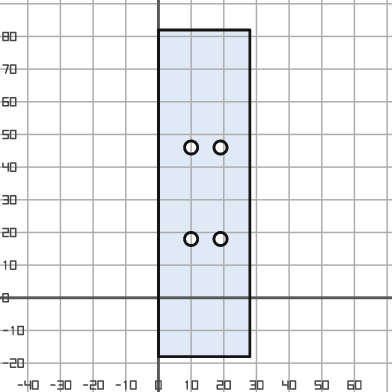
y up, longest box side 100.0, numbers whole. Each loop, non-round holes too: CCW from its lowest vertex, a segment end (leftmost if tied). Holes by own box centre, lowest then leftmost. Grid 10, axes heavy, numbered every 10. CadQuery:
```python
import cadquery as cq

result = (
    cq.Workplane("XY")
    .moveTo(0.0, -18.0)
    .lineTo(28.0, -18.0)
    .lineTo(28.0, 82.0)
    .lineTo(0.0, 82.0)
    .close()
    .moveTo(10.0, 18.0)
    .circle(2.0)
    .moveTo(19.0, 18.0)
    .circle(2.0)
    .moveTo(10.0, 46.0)
    .circle(2.0)
    .moveTo(19.0, 46.0)
    .circle(2.0)
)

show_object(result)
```